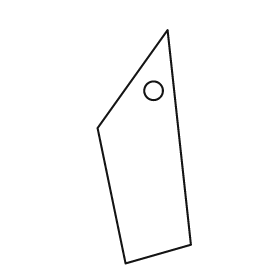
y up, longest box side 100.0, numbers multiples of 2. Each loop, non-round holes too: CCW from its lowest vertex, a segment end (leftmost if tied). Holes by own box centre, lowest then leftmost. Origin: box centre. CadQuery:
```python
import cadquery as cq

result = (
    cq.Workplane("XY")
    .moveTo(-8.0, -50.0)
    .lineTo(20.0, -42.0)
    .lineTo(10.0, 50.0)
    .lineTo(-20.0, 8.0)
    .close()
    .moveTo(4.0, 24.0)
    .circle(4.0)
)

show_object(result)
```